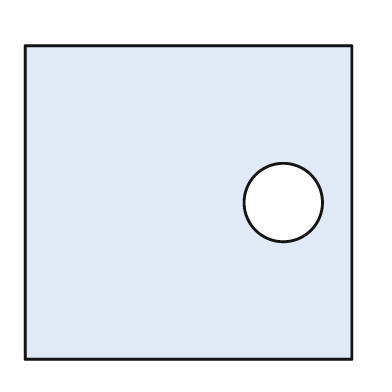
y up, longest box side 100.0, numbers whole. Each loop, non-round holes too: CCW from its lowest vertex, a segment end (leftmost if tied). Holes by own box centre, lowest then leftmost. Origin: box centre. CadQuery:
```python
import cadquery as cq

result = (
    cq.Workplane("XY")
    .moveTo(-50.0, -48.0)
    .lineTo(50.0, -48.0)
    .lineTo(50.0, 48.0)
    .lineTo(-50.0, 48.0)
    .close()
    .moveTo(29.0, 0.0)
    .circle(12.0)
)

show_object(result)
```